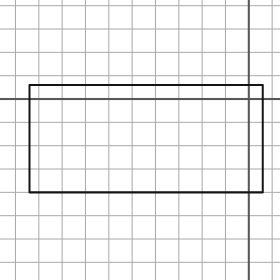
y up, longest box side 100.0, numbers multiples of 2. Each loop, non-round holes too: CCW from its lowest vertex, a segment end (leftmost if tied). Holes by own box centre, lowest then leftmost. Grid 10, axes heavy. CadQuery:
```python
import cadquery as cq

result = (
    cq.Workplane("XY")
    .moveTo(-94.0, -40.0)
    .lineTo(6.0, -40.0)
    .lineTo(6.0, 6.0)
    .lineTo(-94.0, 6.0)
    .close()
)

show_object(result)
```